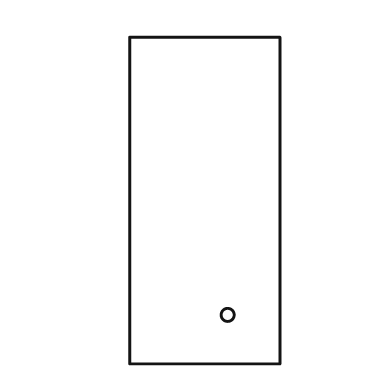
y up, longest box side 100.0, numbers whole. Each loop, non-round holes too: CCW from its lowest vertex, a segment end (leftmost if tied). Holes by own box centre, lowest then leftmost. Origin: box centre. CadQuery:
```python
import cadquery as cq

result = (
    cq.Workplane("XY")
    .moveTo(-23.0, -50.0)
    .lineTo(23.0, -50.0)
    .lineTo(23.0, 50.0)
    .lineTo(-23.0, 50.0)
    .close()
    .moveTo(7.0, -35.0)
    .circle(2.0)
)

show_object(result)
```